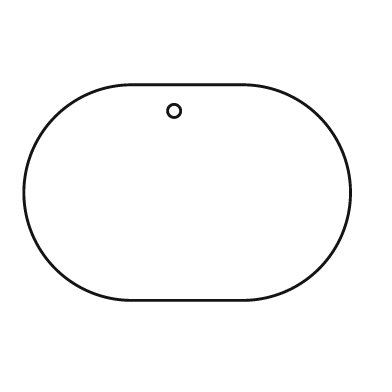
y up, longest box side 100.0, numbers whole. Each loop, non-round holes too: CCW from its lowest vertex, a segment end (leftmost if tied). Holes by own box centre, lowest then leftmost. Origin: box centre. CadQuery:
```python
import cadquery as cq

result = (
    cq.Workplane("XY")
    .moveTo(-17.0, -33.0)
    .lineTo(17.0, -33.0)
    .threePointArc((50.0, 0.0), (17.0, 33.0))
    .lineTo(-17.0, 33.0)
    .threePointArc((-50.0, 0.0), (-17.0, -33.0))
    .close()
    .moveTo(-4.0, 25.0)
    .circle(2.0)
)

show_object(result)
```